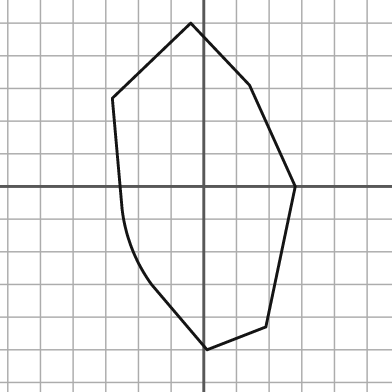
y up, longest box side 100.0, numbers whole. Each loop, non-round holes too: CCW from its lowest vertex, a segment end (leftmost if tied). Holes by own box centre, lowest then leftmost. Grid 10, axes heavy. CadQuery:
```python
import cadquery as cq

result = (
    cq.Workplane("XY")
    .moveTo(1.0, -50.0)
    .lineTo(19.0, -43.0)
    .lineTo(28.0, 0.0)
    .lineTo(14.0, 31.0)
    .lineTo(-4.0, 50.0)
    .lineTo(-28.0, 27.0)
    .lineTo(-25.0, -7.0)
    .threePointArc((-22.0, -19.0), (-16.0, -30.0))
    .close()
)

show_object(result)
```